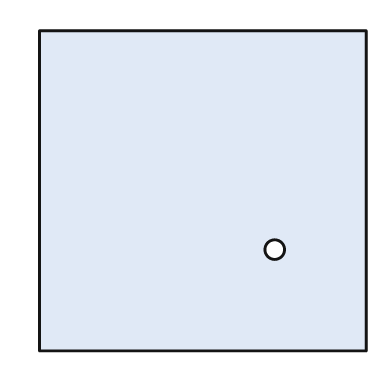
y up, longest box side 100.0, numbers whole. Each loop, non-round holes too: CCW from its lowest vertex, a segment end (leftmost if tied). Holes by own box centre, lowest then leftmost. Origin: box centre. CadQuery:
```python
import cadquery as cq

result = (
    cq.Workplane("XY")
    .moveTo(-50.0, -49.0)
    .lineTo(50.0, -49.0)
    .lineTo(50.0, 49.0)
    .lineTo(-50.0, 49.0)
    .close()
    .moveTo(22.0, -18.0)
    .circle(3.0)
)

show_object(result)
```